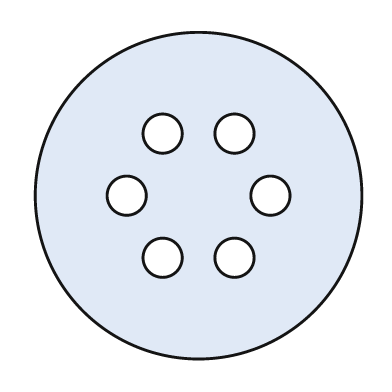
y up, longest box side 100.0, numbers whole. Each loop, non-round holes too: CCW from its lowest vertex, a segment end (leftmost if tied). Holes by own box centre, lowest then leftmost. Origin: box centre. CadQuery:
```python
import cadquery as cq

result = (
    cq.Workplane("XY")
    .moveTo(0.0, 0.0)
    .circle(50.0)
    .moveTo(-11.0, -19.0)
    .circle(6.0)
    .moveTo(11.0, -19.0)
    .circle(6.0)
    .moveTo(-22.0, 0.0)
    .circle(6.0)
    .moveTo(22.0, 0.0)
    .circle(6.0)
    .moveTo(-11.0, 19.0)
    .circle(6.0)
    .moveTo(11.0, 19.0)
    .circle(6.0)
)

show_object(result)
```